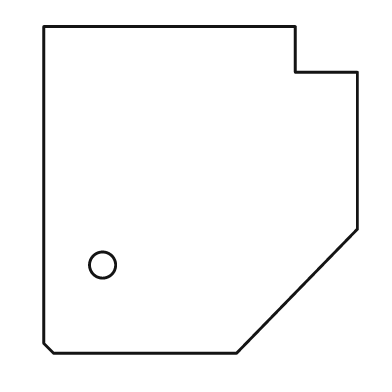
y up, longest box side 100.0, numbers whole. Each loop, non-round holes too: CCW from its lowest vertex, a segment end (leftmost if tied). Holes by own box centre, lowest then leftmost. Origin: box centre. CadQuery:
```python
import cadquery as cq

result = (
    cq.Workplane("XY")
    .moveTo(-45.0, -50.0)
    .lineTo(11.0, -50.0)
    .lineTo(48.0, -12.0)
    .lineTo(48.0, 36.0)
    .lineTo(29.0, 36.0)
    .lineTo(29.0, 50.0)
    .lineTo(-48.0, 50.0)
    .lineTo(-48.0, -47.0)
    .close()
    .moveTo(-30.0, -23.0)
    .circle(4.0)
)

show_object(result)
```